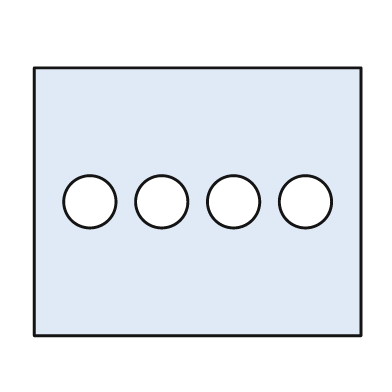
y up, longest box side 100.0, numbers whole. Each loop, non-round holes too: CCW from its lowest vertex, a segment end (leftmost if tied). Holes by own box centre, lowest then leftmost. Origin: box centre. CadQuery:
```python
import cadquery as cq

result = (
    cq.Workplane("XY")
    .moveTo(-50.0, -41.0)
    .lineTo(50.0, -41.0)
    .lineTo(50.0, 41.0)
    .lineTo(-50.0, 41.0)
    .close()
    .moveTo(-33.0, 0.0)
    .circle(8.0)
    .moveTo(-11.0, 0.0)
    .circle(8.0)
    .moveTo(11.0, 0.0)
    .circle(8.0)
    .moveTo(33.0, 0.0)
    .circle(8.0)
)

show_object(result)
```